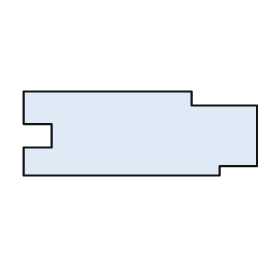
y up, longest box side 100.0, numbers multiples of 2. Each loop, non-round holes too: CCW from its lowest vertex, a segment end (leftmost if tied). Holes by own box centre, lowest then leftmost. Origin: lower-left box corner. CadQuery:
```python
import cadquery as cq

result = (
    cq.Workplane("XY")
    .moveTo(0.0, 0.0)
    .lineTo(84.0, 0.0)
    .lineTo(84.0, 4.0)
    .lineTo(100.0, 4.0)
    .lineTo(100.0, 30.0)
    .lineTo(72.0, 30.0)
    .lineTo(72.0, 36.0)
    .lineTo(0.0, 36.0)
    .lineTo(0.0, 22.0)
    .lineTo(12.0, 22.0)
    .lineTo(12.0, 12.0)
    .lineTo(0.0, 12.0)
    .close()
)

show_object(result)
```